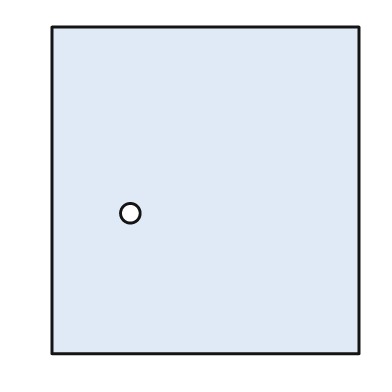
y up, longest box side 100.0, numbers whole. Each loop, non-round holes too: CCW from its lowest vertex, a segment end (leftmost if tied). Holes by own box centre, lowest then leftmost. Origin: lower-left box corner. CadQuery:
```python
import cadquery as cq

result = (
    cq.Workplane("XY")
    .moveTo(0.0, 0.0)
    .lineTo(94.0, 0.0)
    .lineTo(94.0, 100.0)
    .lineTo(0.0, 100.0)
    .close()
    .moveTo(24.0, 43.0)
    .circle(3.0)
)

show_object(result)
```